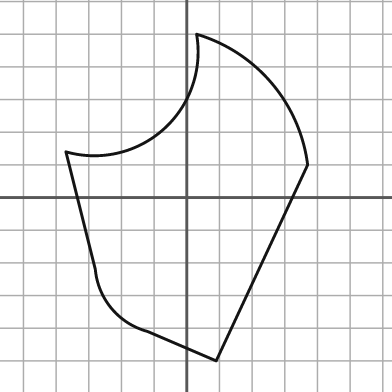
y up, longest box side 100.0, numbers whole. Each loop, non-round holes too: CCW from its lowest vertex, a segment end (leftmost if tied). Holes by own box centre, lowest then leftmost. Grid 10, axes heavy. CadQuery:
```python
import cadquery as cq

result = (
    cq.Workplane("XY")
    .moveTo(9.0, -50.0)
    .lineTo(37.0, 10.0)
    .threePointArc((26.0, 35.0), (3.0, 50.0))
    .threePointArc((-7.0, 21.0), (-37.0, 14.0))
    .lineTo(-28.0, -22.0)
    .threePointArc((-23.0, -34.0), (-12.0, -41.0))
    .close()
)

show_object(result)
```